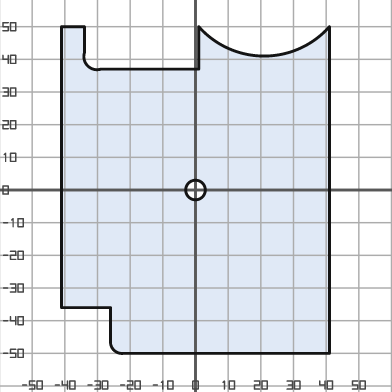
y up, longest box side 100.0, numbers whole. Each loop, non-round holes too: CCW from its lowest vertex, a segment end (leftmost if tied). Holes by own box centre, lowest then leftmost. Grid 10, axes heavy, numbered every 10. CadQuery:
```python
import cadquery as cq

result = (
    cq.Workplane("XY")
    .moveTo(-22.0, -50.0)
    .lineTo(41.0, -50.0)
    .lineTo(41.0, 50.0)
    .threePointArc((21.0, 41.0), (1.0, 50.0))
    .lineTo(1.0, 37.0)
    .lineTo(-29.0, 37.0)
    .threePointArc((-33.0, 38.0), (-34.0, 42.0))
    .lineTo(-34.0, 50.0)
    .lineTo(-41.0, 50.0)
    .lineTo(-41.0, -36.0)
    .lineTo(-26.0, -36.0)
    .lineTo(-26.0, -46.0)
    .threePointArc((-25.0, -49.0), (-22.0, -50.0))
    .close()
    .moveTo(0.0, 0.0)
    .circle(3.0)
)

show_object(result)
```